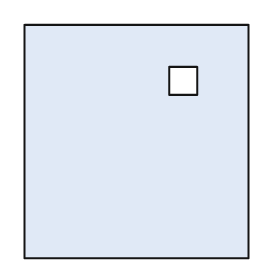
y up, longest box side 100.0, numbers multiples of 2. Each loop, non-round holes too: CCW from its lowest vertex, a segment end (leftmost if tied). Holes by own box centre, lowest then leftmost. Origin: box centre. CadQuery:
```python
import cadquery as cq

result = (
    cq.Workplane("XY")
    .moveTo(-48.0, -50.0)
    .lineTo(48.0, -50.0)
    .lineTo(48.0, 50.0)
    .lineTo(-48.0, 50.0)
    .close()
    .moveTo(14.0, 20.0)
    .lineTo(26.0, 20.0)
    .lineTo(26.0, 32.0)
    .lineTo(14.0, 32.0)
    .close()
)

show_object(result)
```